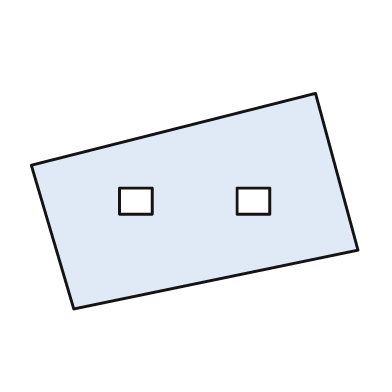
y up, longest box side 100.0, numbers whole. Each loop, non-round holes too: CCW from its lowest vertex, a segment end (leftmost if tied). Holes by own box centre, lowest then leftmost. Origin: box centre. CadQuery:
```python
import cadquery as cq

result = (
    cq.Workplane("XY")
    .moveTo(-37.0, -33.0)
    .lineTo(50.0, -15.0)
    .lineTo(37.0, 33.0)
    .lineTo(-50.0, 11.0)
    .close()
    .moveTo(-23.0, -4.0)
    .lineTo(-13.0, -4.0)
    .lineTo(-13.0, 4.0)
    .lineTo(-23.0, 4.0)
    .close()
    .moveTo(13.0, -4.0)
    .lineTo(23.0, -4.0)
    .lineTo(23.0, 4.0)
    .lineTo(13.0, 4.0)
    .close()
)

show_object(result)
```